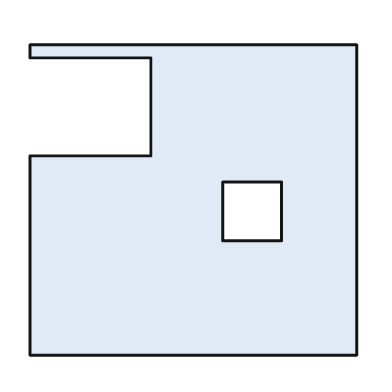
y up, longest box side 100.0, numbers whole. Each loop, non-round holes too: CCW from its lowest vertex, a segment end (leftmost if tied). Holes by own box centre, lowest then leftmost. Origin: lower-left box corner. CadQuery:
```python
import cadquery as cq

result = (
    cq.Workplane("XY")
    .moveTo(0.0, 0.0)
    .lineTo(100.0, 0.0)
    .lineTo(100.0, 95.0)
    .lineTo(0.0, 95.0)
    .lineTo(0.0, 91.0)
    .lineTo(37.0, 91.0)
    .lineTo(37.0, 61.0)
    .lineTo(0.0, 61.0)
    .close()
    .moveTo(59.0, 35.0)
    .lineTo(77.0, 35.0)
    .lineTo(77.0, 53.0)
    .lineTo(59.0, 53.0)
    .close()
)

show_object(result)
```